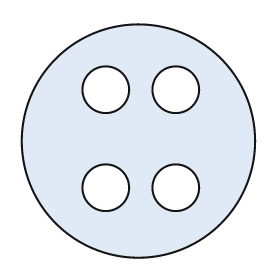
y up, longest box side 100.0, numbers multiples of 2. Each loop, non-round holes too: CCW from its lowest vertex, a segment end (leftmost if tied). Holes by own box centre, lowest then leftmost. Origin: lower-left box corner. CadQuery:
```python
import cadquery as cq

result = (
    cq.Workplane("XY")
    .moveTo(50.0, 50.0)
    .circle(50.0)
    .moveTo(36.0, 30.0)
    .circle(10.0)
    .moveTo(66.0, 30.0)
    .circle(10.0)
    .moveTo(36.0, 72.0)
    .circle(10.0)
    .moveTo(66.0, 72.0)
    .circle(10.0)
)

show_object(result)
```